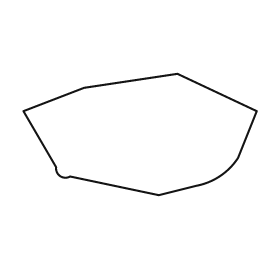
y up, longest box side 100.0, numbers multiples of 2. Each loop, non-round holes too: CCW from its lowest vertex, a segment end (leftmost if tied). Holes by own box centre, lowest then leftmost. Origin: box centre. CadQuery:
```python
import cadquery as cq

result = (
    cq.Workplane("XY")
    .moveTo(8.0, -26.0)
    .lineTo(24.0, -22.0)
    .threePointArc((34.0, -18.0), (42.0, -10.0))
    .lineTo(50.0, 10.0)
    .lineTo(16.0, 26.0)
    .lineTo(-24.0, 20.0)
    .lineTo(-50.0, 10.0)
    .lineTo(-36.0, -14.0)
    .threePointArc((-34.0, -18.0), (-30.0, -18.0))
    .close()
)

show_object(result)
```